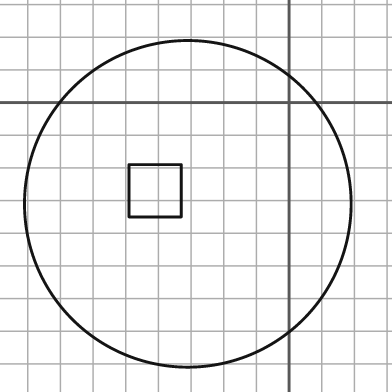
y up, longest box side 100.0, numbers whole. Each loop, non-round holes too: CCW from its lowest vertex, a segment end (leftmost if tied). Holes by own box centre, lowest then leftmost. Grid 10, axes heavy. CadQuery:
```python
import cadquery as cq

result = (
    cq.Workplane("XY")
    .moveTo(-31.0, -31.0)
    .circle(50.0)
    .moveTo(-49.0, -35.0)
    .lineTo(-33.0, -35.0)
    .lineTo(-33.0, -19.0)
    .lineTo(-49.0, -19.0)
    .close()
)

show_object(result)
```